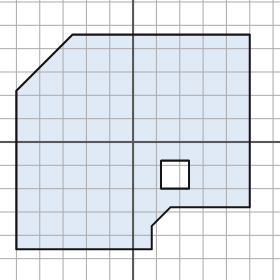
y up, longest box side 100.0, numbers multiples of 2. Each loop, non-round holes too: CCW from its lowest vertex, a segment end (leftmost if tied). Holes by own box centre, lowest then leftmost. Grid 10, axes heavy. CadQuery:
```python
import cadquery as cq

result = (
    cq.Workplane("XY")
    .moveTo(-50.0, -46.0)
    .lineTo(8.0, -46.0)
    .lineTo(8.0, -36.0)
    .lineTo(16.0, -28.0)
    .lineTo(50.0, -28.0)
    .lineTo(50.0, 46.0)
    .lineTo(-26.0, 46.0)
    .lineTo(-50.0, 22.0)
    .close()
    .moveTo(12.0, -20.0)
    .lineTo(24.0, -20.0)
    .lineTo(24.0, -8.0)
    .lineTo(12.0, -8.0)
    .close()
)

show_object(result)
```